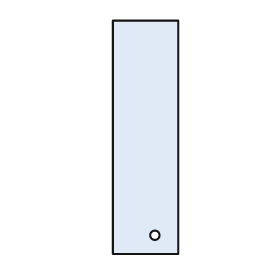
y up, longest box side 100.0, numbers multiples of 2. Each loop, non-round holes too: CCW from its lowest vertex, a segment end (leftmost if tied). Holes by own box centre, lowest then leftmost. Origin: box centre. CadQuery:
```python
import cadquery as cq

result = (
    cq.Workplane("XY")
    .moveTo(-14.0, -50.0)
    .lineTo(14.0, -50.0)
    .lineTo(14.0, 50.0)
    .lineTo(-14.0, 50.0)
    .close()
    .moveTo(4.0, -42.0)
    .circle(2.0)
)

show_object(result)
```